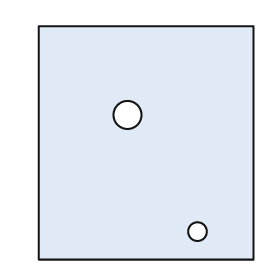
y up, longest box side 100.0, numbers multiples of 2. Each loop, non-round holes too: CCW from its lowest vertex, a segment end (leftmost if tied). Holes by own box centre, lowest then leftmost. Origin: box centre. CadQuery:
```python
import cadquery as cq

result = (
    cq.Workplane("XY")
    .moveTo(-46.0, -50.0)
    .lineTo(46.0, -50.0)
    .lineTo(46.0, 50.0)
    .lineTo(-46.0, 50.0)
    .close()
    .moveTo(22.0, -38.0)
    .circle(4.0)
    .moveTo(-8.0, 12.0)
    .circle(6.0)
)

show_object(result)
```